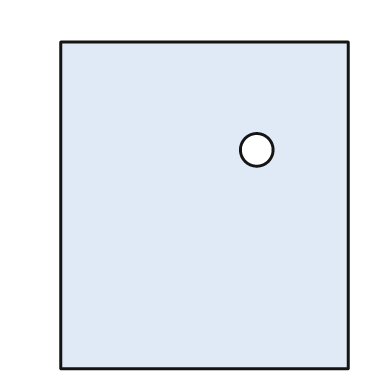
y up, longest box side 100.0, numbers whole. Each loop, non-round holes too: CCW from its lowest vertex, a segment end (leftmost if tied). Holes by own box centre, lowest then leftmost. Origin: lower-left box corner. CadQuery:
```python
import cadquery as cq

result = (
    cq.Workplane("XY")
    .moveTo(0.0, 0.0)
    .lineTo(88.0, 0.0)
    .lineTo(88.0, 100.0)
    .lineTo(0.0, 100.0)
    .close()
    .moveTo(60.0, 67.0)
    .circle(5.0)
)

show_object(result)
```